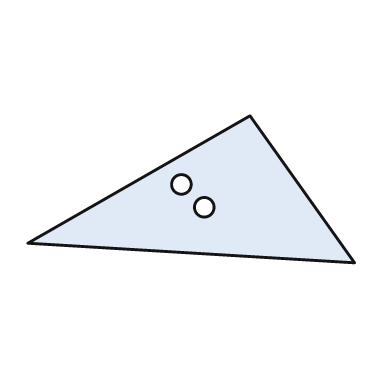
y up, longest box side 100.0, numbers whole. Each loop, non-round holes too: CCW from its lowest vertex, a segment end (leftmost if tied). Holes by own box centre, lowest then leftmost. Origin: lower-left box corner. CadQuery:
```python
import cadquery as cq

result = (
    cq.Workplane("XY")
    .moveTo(100.0, 0.0)
    .lineTo(68.0, 45.0)
    .lineTo(0.0, 6.0)
    .close()
    .moveTo(54.0, 17.0)
    .circle(3.0)
    .moveTo(47.0, 24.0)
    .circle(3.0)
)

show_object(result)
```